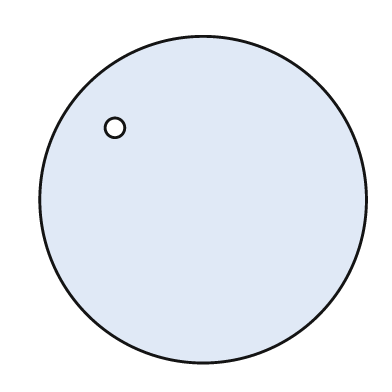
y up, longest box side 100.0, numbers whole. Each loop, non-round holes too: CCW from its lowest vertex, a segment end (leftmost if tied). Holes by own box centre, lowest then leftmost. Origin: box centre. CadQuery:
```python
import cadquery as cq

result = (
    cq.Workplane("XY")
    .moveTo(0.0, 0.0)
    .circle(50.0)
    .moveTo(-27.0, 22.0)
    .circle(3.0)
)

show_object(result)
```